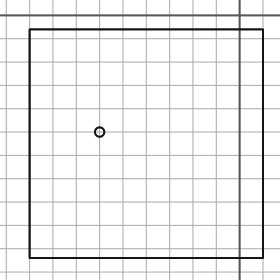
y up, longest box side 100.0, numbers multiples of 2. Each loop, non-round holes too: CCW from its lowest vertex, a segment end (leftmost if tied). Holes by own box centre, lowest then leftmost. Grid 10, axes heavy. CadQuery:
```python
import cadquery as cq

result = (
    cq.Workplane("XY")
    .moveTo(-90.0, -104.0)
    .lineTo(10.0, -104.0)
    .lineTo(10.0, -6.0)
    .lineTo(-90.0, -6.0)
    .close()
    .moveTo(-60.0, -50.0)
    .circle(2.0)
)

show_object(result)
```